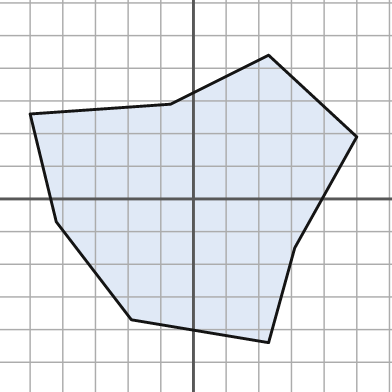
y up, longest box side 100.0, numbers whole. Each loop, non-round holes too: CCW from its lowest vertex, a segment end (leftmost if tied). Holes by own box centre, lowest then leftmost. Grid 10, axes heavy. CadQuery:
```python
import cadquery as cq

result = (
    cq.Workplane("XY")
    .moveTo(23.0, -44.0)
    .lineTo(31.0, -15.0)
    .lineTo(50.0, 19.0)
    .lineTo(23.0, 44.0)
    .lineTo(-7.0, 29.0)
    .lineTo(-50.0, 26.0)
    .lineTo(-42.0, -7.0)
    .lineTo(-19.0, -37.0)
    .close()
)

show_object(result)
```